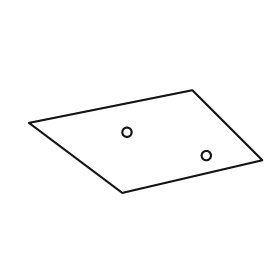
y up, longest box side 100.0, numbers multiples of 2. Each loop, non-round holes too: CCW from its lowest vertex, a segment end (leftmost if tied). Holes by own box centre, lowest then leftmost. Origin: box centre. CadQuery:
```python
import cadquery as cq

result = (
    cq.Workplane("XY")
    .moveTo(-10.0, -22.0)
    .lineTo(50.0, -8.0)
    .lineTo(20.0, 22.0)
    .lineTo(-50.0, 8.0)
    .close()
    .moveTo(26.0, -6.0)
    .circle(2.0)
    .moveTo(-8.0, 4.0)
    .circle(2.0)
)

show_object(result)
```